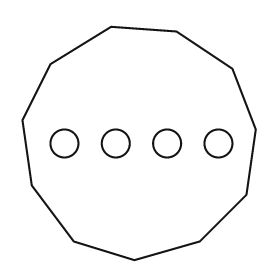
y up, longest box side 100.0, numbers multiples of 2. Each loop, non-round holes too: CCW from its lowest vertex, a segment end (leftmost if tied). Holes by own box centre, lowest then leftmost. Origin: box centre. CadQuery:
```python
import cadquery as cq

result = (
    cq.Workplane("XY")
    .moveTo(-2.0, -50.0)
    .lineTo(26.0, -42.0)
    .lineTo(46.0, -22.0)
    .lineTo(50.0, 6.0)
    .lineTo(40.0, 32.0)
    .lineTo(16.0, 48.0)
    .lineTo(-12.0, 50.0)
    .lineTo(-38.0, 34.0)
    .lineTo(-50.0, 10.0)
    .lineTo(-46.0, -18.0)
    .lineTo(-28.0, -42.0)
    .close()
    .moveTo(-32.0, 0.0)
    .circle(6.0)
    .moveTo(-10.0, 0.0)
    .circle(6.0)
    .moveTo(12.0, 0.0)
    .circle(6.0)
    .moveTo(34.0, 0.0)
    .circle(6.0)
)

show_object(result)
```